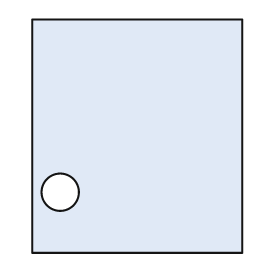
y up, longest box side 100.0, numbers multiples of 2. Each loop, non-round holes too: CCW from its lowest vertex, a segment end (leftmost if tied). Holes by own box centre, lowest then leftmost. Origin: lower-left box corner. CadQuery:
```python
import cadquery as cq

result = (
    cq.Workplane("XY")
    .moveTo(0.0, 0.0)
    .lineTo(90.0, 0.0)
    .lineTo(90.0, 100.0)
    .lineTo(0.0, 100.0)
    .close()
    .moveTo(12.0, 26.0)
    .circle(8.0)
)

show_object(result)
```